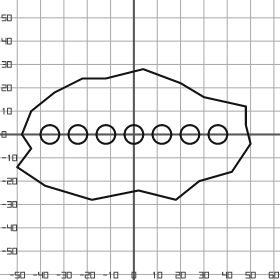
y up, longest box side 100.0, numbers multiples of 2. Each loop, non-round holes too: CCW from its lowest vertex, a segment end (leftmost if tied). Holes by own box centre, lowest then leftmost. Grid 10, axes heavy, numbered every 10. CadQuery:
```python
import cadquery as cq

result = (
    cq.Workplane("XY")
    .moveTo(-18.0, -28.0)
    .lineTo(2.0, -24.0)
    .lineTo(18.0, -28.0)
    .lineTo(28.0, -20.0)
    .lineTo(42.0, -16.0)
    .lineTo(50.0, -4.0)
    .lineTo(48.0, 4.0)
    .lineTo(48.0, 12.0)
    .lineTo(30.0, 16.0)
    .lineTo(20.0, 22.0)
    .lineTo(4.0, 28.0)
    .lineTo(-12.0, 24.0)
    .lineTo(-22.0, 24.0)
    .lineTo(-34.0, 18.0)
    .lineTo(-44.0, 10.0)
    .lineTo(-48.0, 0.0)
    .lineTo(-44.0, -6.0)
    .lineTo(-50.0, -14.0)
    .lineTo(-38.0, -22.0)
    .close()
    .moveTo(-36.0, 0.0)
    .circle(4.0)
    .moveTo(-24.0, 0.0)
    .circle(4.0)
    .moveTo(-12.0, 0.0)
    .circle(4.0)
    .moveTo(0.0, 0.0)
    .circle(4.0)
    .moveTo(12.0, 0.0)
    .circle(4.0)
    .moveTo(24.0, 0.0)
    .circle(4.0)
    .moveTo(36.0, 0.0)
    .circle(4.0)
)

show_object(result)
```